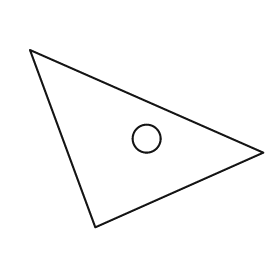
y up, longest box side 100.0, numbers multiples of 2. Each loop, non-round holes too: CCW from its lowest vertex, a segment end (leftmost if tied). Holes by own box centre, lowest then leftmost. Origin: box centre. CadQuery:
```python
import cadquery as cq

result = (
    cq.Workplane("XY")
    .moveTo(-22.0, -38.0)
    .lineTo(50.0, -6.0)
    .lineTo(-50.0, 38.0)
    .close()
    .moveTo(0.0, 0.0)
    .circle(6.0)
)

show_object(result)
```